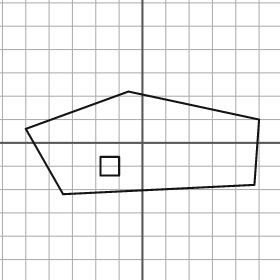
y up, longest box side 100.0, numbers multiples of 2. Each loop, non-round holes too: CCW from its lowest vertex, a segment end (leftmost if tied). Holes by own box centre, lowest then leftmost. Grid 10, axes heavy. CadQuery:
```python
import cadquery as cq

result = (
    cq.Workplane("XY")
    .moveTo(-34.0, -22.0)
    .lineTo(48.0, -18.0)
    .lineTo(50.0, 10.0)
    .lineTo(-6.0, 22.0)
    .lineTo(-50.0, 6.0)
    .close()
    .moveTo(-18.0, -14.0)
    .lineTo(-10.0, -14.0)
    .lineTo(-10.0, -6.0)
    .lineTo(-18.0, -6.0)
    .close()
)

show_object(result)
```